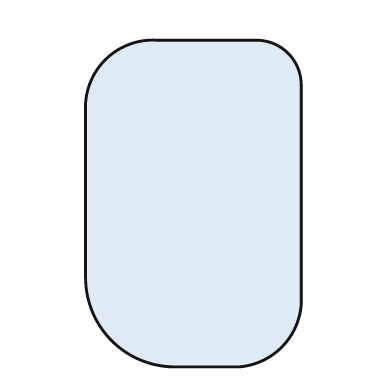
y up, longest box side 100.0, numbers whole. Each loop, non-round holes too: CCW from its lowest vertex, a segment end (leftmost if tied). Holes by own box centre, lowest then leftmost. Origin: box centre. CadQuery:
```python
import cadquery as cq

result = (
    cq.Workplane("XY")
    .moveTo(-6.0, -50.0)
    .lineTo(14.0, -50.0)
    .threePointArc((27.0, -44.0), (33.0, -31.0))
    .lineTo(33.0, 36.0)
    .threePointArc((29.0, 46.0), (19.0, 50.0))
    .lineTo(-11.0, 50.0)
    .threePointArc((-27.0, 44.0), (-33.0, 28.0))
    .lineTo(-33.0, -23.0)
    .threePointArc((-25.0, -42.0), (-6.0, -50.0))
    .close()
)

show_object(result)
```